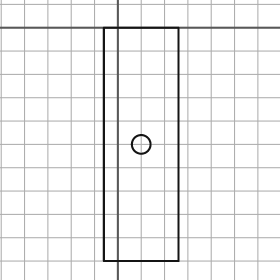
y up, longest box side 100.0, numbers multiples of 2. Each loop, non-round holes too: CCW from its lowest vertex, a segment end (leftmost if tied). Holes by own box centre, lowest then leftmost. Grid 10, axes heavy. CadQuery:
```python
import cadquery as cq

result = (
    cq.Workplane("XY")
    .moveTo(-6.0, -100.0)
    .lineTo(26.0, -100.0)
    .lineTo(26.0, 0.0)
    .lineTo(-6.0, 0.0)
    .close()
    .moveTo(10.0, -50.0)
    .circle(4.0)
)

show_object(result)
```